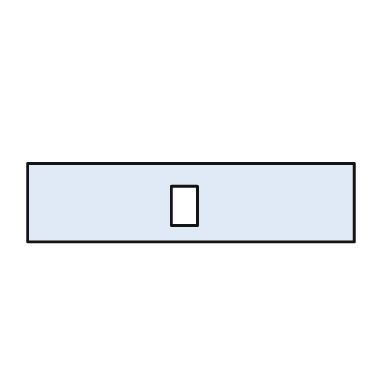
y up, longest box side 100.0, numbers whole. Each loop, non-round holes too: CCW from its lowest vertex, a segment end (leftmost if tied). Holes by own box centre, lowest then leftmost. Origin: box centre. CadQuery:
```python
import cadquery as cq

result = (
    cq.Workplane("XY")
    .moveTo(-50.0, -12.0)
    .lineTo(50.0, -12.0)
    .lineTo(50.0, 12.0)
    .lineTo(-50.0, 12.0)
    .close()
    .moveTo(-6.0, -7.0)
    .lineTo(2.0, -7.0)
    .lineTo(2.0, 5.0)
    .lineTo(-6.0, 5.0)
    .close()
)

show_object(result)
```